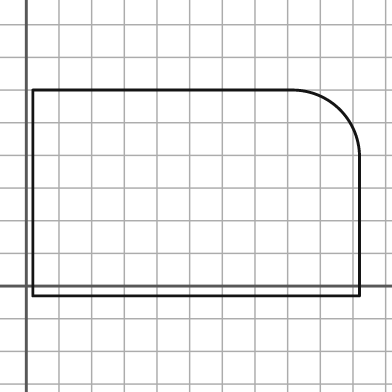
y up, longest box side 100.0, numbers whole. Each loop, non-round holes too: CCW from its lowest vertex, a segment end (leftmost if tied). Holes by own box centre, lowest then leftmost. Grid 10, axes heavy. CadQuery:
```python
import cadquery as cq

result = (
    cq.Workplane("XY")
    .moveTo(2.0, -3.0)
    .lineTo(102.0, -3.0)
    .lineTo(102.0, 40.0)
    .threePointArc((96.0, 54.0), (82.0, 60.0))
    .lineTo(2.0, 60.0)
    .close()
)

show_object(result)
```